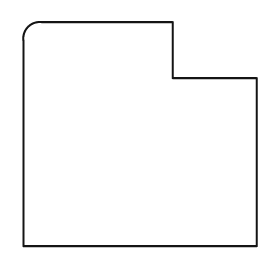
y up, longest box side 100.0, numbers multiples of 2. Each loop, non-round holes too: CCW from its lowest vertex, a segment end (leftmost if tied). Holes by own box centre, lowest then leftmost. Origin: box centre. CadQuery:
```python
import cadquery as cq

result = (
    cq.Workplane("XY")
    .moveTo(-50.0, -48.0)
    .lineTo(50.0, -48.0)
    .lineTo(50.0, 24.0)
    .lineTo(14.0, 24.0)
    .lineTo(14.0, 48.0)
    .lineTo(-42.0, 48.0)
    .threePointArc((-48.0, 46.0), (-50.0, 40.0))
    .close()
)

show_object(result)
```